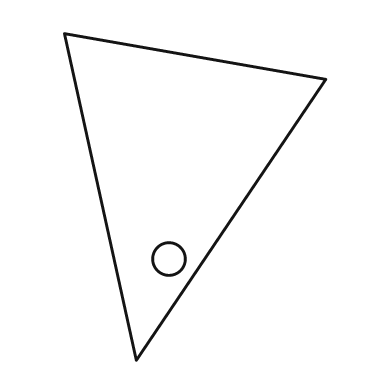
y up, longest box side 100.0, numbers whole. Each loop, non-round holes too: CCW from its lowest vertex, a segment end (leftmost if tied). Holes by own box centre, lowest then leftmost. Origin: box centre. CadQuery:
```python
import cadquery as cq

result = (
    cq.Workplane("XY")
    .moveTo(-18.0, -50.0)
    .lineTo(40.0, 36.0)
    .lineTo(-40.0, 50.0)
    .close()
    .moveTo(-8.0, -19.0)
    .circle(5.0)
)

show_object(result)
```